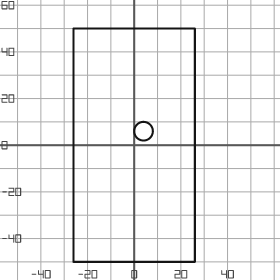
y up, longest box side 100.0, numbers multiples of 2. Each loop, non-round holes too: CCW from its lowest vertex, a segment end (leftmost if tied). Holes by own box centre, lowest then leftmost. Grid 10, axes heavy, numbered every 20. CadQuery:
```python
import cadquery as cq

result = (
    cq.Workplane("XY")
    .moveTo(-26.0, -50.0)
    .lineTo(26.0, -50.0)
    .lineTo(26.0, 50.0)
    .lineTo(-26.0, 50.0)
    .close()
    .moveTo(4.0, 6.0)
    .circle(4.0)
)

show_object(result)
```